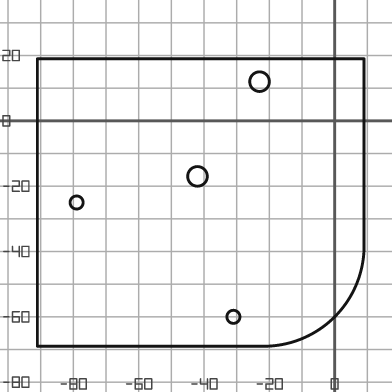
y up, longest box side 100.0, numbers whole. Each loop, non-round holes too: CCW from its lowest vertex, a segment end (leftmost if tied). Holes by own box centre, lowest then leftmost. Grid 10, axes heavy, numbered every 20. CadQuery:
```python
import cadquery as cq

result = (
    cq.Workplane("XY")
    .moveTo(-91.0, -69.0)
    .lineTo(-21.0, -69.0)
    .threePointArc((0.0, -60.0), (9.0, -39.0))
    .lineTo(9.0, 19.0)
    .lineTo(-91.0, 19.0)
    .close()
    .moveTo(-31.0, -60.0)
    .circle(2.0)
    .moveTo(-79.0, -25.0)
    .circle(2.0)
    .moveTo(-42.0, -17.0)
    .circle(3.0)
    .moveTo(-23.0, 12.0)
    .circle(3.0)
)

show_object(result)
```